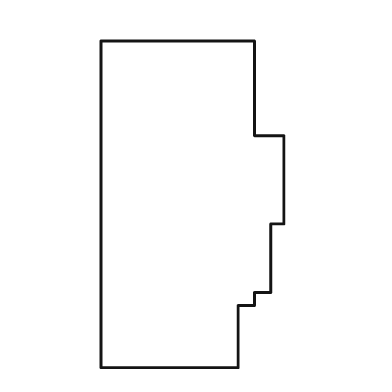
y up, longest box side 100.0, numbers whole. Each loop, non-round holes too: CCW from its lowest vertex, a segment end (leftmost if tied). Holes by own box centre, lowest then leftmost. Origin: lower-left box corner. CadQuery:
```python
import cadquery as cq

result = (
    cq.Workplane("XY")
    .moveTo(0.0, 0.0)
    .lineTo(42.0, 0.0)
    .lineTo(42.0, 19.0)
    .lineTo(47.0, 19.0)
    .lineTo(47.0, 23.0)
    .lineTo(52.0, 23.0)
    .lineTo(52.0, 44.0)
    .lineTo(56.0, 44.0)
    .lineTo(56.0, 71.0)
    .lineTo(47.0, 71.0)
    .lineTo(47.0, 100.0)
    .lineTo(0.0, 100.0)
    .close()
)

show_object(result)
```